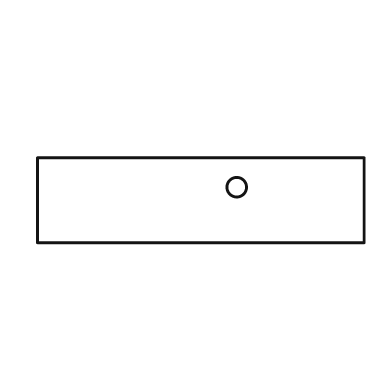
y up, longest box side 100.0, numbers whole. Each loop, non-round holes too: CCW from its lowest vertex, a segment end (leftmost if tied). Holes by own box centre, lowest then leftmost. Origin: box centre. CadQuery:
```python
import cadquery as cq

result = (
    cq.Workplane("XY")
    .moveTo(-50.0, -13.0)
    .lineTo(50.0, -13.0)
    .lineTo(50.0, 13.0)
    .lineTo(-50.0, 13.0)
    .close()
    .moveTo(11.0, 4.0)
    .circle(3.0)
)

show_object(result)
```